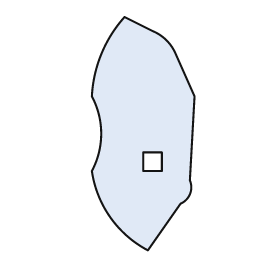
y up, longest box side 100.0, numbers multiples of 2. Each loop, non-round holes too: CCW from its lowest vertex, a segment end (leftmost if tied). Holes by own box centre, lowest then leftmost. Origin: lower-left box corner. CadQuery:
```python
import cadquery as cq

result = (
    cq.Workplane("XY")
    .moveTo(24.0, 0.0)
    .lineTo(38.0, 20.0)
    .threePointArc((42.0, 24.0), (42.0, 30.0))
    .lineTo(44.0, 66.0)
    .lineTo(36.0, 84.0)
    .threePointArc((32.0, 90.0), (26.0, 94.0))
    .lineTo(14.0, 100.0)
    .threePointArc((4.0, 84.0), (0.0, 66.0))
    .threePointArc((4.0, 50.0), (0.0, 34.0))
    .threePointArc((8.0, 14.0), (24.0, 0.0))
    .close()
    .moveTo(22.0, 34.0)
    .lineTo(30.0, 34.0)
    .lineTo(30.0, 42.0)
    .lineTo(22.0, 42.0)
    .close()
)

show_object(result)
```